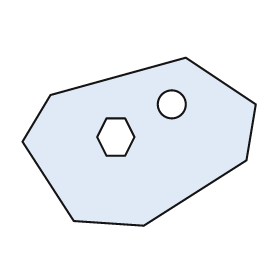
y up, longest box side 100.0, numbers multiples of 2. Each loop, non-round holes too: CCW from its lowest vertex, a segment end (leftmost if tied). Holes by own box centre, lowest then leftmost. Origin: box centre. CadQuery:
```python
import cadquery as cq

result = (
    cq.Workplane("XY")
    .moveTo(2.0, -36.0)
    .lineTo(46.0, -8.0)
    .lineTo(50.0, 16.0)
    .lineTo(20.0, 36.0)
    .lineTo(-38.0, 20.0)
    .lineTo(-50.0, 0.0)
    .lineTo(-28.0, -34.0)
    .close()
    .moveTo(-14.0, -6.0)
    .lineTo(-6.0, -6.0)
    .lineTo(-2.0, 2.0)
    .lineTo(-6.0, 10.0)
    .lineTo(-14.0, 10.0)
    .lineTo(-18.0, 2.0)
    .close()
    .moveTo(14.0, 16.0)
    .circle(6.0)
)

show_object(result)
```